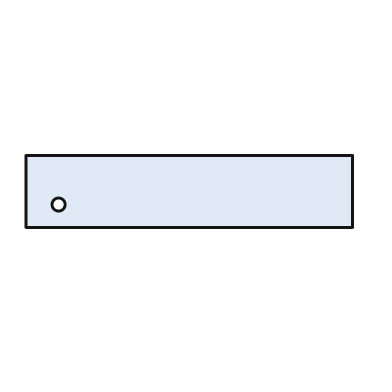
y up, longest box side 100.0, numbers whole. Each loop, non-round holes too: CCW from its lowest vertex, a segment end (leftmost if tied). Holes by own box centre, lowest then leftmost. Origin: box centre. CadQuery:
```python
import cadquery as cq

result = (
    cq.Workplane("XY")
    .moveTo(-50.0, -11.0)
    .lineTo(50.0, -11.0)
    .lineTo(50.0, 11.0)
    .lineTo(-50.0, 11.0)
    .close()
    .moveTo(-40.0, -4.0)
    .circle(2.0)
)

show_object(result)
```